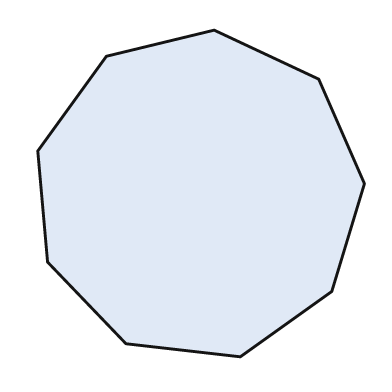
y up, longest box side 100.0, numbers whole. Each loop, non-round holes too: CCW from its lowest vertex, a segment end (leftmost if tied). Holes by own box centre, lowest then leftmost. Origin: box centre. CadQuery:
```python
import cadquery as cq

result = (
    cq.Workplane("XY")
    .moveTo(12.0, -50.0)
    .lineTo(40.0, -30.0)
    .lineTo(50.0, 3.0)
    .lineTo(36.0, 35.0)
    .lineTo(4.0, 50.0)
    .lineTo(-29.0, 42.0)
    .lineTo(-50.0, 13.0)
    .lineTo(-47.0, -21.0)
    .lineTo(-23.0, -46.0)
    .close()
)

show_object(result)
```